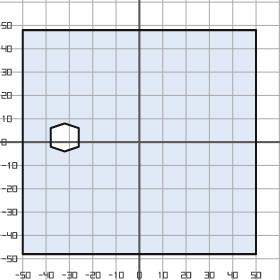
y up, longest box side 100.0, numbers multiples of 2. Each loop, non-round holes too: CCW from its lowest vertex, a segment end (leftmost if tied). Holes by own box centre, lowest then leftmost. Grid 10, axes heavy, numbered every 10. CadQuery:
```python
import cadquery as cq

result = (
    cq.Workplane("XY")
    .moveTo(-50.0, -48.0)
    .lineTo(50.0, -48.0)
    .lineTo(50.0, 48.0)
    .lineTo(-50.0, 48.0)
    .close()
    .moveTo(-32.0, -4.0)
    .lineTo(-26.0, -2.0)
    .lineTo(-26.0, 6.0)
    .lineTo(-32.0, 8.0)
    .lineTo(-38.0, 6.0)
    .lineTo(-38.0, -2.0)
    .close()
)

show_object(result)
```